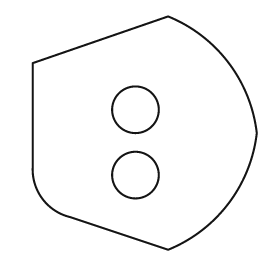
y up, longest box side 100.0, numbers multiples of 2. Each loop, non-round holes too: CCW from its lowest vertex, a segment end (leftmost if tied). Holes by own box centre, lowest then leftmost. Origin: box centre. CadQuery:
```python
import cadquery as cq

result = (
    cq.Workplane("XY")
    .moveTo(10.0, -50.0)
    .threePointArc((36.0, -30.0), (48.0, 0.0))
    .threePointArc((36.0, 30.0), (10.0, 50.0))
    .lineTo(-48.0, 30.0)
    .lineTo(-48.0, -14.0)
    .threePointArc((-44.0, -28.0), (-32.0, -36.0))
    .close()
    .moveTo(-4.0, -18.0)
    .circle(10.0)
    .moveTo(-4.0, 10.0)
    .circle(10.0)
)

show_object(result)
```